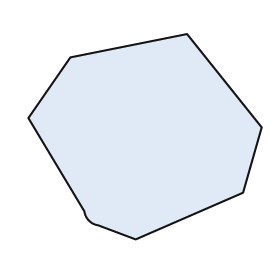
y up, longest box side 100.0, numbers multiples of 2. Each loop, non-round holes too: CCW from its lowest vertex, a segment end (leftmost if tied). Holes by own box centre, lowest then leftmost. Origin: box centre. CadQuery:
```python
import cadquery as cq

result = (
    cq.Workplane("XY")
    .moveTo(-4.0, -44.0)
    .lineTo(42.0, -24.0)
    .lineTo(50.0, 4.0)
    .lineTo(18.0, 44.0)
    .lineTo(-32.0, 34.0)
    .lineTo(-50.0, 8.0)
    .lineTo(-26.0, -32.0)
    .threePointArc((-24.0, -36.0), (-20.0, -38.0))
    .close()
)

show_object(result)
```